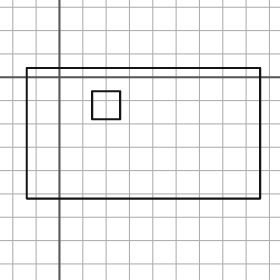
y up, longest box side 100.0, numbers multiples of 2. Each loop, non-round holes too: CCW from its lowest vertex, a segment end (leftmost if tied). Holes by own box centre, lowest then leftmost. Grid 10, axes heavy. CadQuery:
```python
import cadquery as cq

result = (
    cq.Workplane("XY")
    .moveTo(-14.0, -52.0)
    .lineTo(86.0, -52.0)
    .lineTo(86.0, 4.0)
    .lineTo(-14.0, 4.0)
    .close()
    .moveTo(14.0, -18.0)
    .lineTo(26.0, -18.0)
    .lineTo(26.0, -6.0)
    .lineTo(14.0, -6.0)
    .close()
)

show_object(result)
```